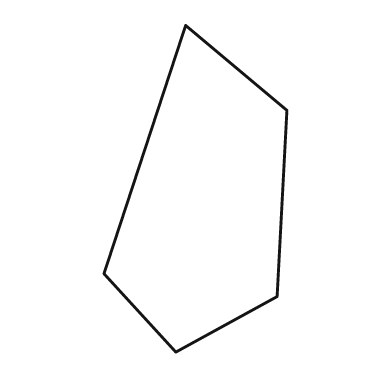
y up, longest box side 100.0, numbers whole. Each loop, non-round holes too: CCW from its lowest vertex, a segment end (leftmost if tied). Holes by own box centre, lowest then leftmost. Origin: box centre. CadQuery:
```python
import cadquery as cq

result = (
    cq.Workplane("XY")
    .moveTo(-6.0, -50.0)
    .lineTo(25.0, -33.0)
    .lineTo(28.0, 24.0)
    .lineTo(-3.0, 50.0)
    .lineTo(-28.0, -26.0)
    .close()
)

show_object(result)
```